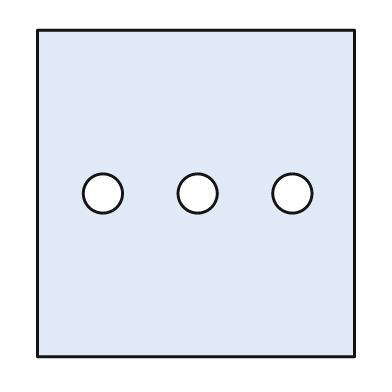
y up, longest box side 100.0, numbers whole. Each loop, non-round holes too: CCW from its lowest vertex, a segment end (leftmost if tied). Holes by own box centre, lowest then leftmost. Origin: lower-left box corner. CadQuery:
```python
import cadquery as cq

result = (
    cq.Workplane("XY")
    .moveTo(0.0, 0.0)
    .lineTo(97.0, 0.0)
    .lineTo(97.0, 100.0)
    .lineTo(0.0, 100.0)
    .close()
    .moveTo(20.0, 50.0)
    .circle(6.0)
    .moveTo(49.0, 50.0)
    .circle(6.0)
    .moveTo(78.0, 50.0)
    .circle(6.0)
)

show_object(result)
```